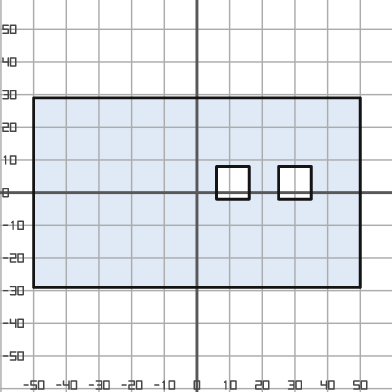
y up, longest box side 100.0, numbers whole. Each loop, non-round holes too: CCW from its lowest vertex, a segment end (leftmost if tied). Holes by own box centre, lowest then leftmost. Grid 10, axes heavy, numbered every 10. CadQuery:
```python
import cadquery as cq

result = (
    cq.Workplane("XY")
    .moveTo(-50.0, -29.0)
    .lineTo(50.0, -29.0)
    .lineTo(50.0, 29.0)
    .lineTo(-50.0, 29.0)
    .close()
    .moveTo(6.0, -2.0)
    .lineTo(16.0, -2.0)
    .lineTo(16.0, 8.0)
    .lineTo(6.0, 8.0)
    .close()
    .moveTo(25.0, -2.0)
    .lineTo(35.0, -2.0)
    .lineTo(35.0, 8.0)
    .lineTo(25.0, 8.0)
    .close()
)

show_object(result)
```